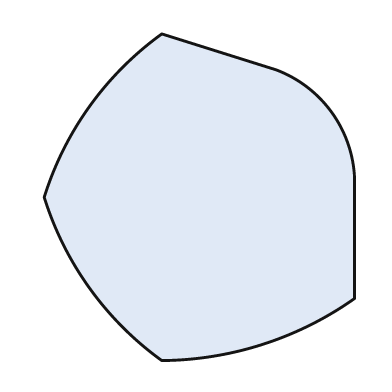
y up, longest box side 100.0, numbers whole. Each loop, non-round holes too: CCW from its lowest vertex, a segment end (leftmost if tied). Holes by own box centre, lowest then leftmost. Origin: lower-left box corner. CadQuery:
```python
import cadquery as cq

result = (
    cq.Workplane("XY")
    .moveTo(36.0, 0.0)
    .threePointArc((67.0, 5.0), (95.0, 19.0))
    .lineTo(95.0, 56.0)
    .threePointArc((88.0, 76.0), (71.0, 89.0))
    .lineTo(36.0, 100.0)
    .threePointArc((14.0, 78.0), (0.0, 50.0))
    .threePointArc((14.0, 22.0), (36.0, 0.0))
    .close()
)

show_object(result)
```